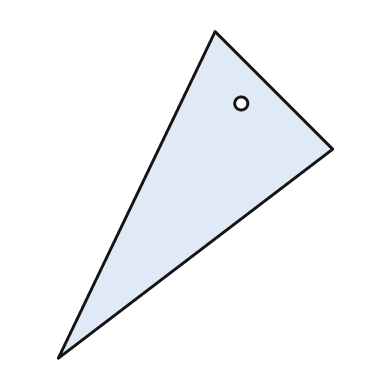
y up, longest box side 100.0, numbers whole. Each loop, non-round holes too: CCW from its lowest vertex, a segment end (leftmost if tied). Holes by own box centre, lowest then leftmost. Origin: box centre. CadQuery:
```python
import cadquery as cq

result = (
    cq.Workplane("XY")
    .moveTo(-42.0, -50.0)
    .lineTo(42.0, 14.0)
    .lineTo(6.0, 50.0)
    .close()
    .moveTo(14.0, 28.0)
    .circle(2.0)
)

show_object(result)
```